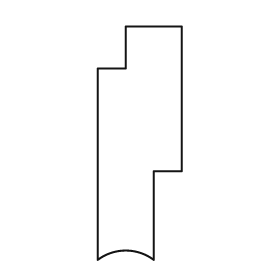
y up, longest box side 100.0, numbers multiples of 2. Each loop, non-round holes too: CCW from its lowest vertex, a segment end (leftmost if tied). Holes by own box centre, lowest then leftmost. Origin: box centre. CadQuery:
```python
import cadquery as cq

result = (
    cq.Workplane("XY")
    .moveTo(-18.0, -50.0)
    .threePointArc((-6.0, -46.0), (6.0, -50.0))
    .lineTo(6.0, -12.0)
    .lineTo(18.0, -12.0)
    .lineTo(18.0, 50.0)
    .lineTo(-6.0, 50.0)
    .lineTo(-6.0, 32.0)
    .lineTo(-18.0, 32.0)
    .close()
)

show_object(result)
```